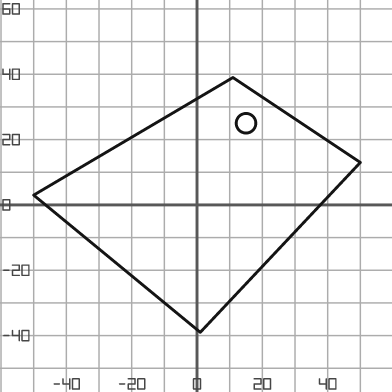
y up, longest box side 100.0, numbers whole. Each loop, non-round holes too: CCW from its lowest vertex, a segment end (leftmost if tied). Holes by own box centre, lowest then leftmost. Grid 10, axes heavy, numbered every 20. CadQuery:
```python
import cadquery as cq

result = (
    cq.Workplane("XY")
    .moveTo(1.0, -39.0)
    .lineTo(50.0, 13.0)
    .lineTo(11.0, 39.0)
    .lineTo(-50.0, 3.0)
    .close()
    .moveTo(15.0, 25.0)
    .circle(3.0)
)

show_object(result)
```